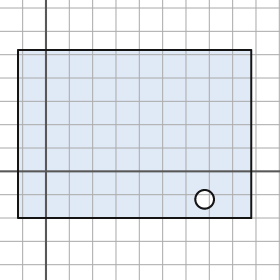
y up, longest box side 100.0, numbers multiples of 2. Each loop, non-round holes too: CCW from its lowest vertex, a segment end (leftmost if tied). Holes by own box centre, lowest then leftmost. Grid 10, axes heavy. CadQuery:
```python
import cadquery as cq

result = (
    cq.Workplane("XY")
    .moveTo(-12.0, -20.0)
    .lineTo(88.0, -20.0)
    .lineTo(88.0, 52.0)
    .lineTo(-12.0, 52.0)
    .close()
    .moveTo(68.0, -12.0)
    .circle(4.0)
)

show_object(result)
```